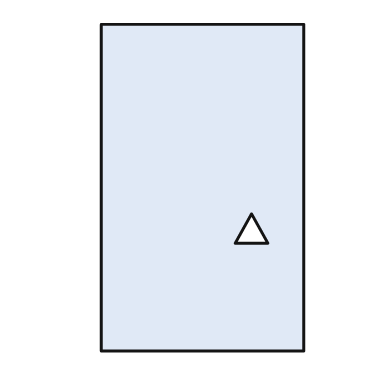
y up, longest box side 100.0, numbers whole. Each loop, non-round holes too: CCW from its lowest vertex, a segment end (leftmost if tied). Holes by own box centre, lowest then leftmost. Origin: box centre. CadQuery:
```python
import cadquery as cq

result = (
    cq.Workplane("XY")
    .moveTo(-31.0, -50.0)
    .lineTo(31.0, -50.0)
    .lineTo(31.0, 50.0)
    .lineTo(-31.0, 50.0)
    .close()
    .moveTo(10.0, -17.0)
    .lineTo(20.0, -17.0)
    .lineTo(15.0, -8.0)
    .close()
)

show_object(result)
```